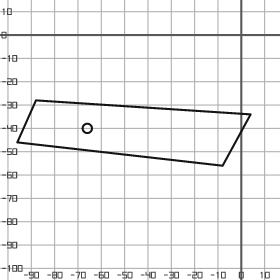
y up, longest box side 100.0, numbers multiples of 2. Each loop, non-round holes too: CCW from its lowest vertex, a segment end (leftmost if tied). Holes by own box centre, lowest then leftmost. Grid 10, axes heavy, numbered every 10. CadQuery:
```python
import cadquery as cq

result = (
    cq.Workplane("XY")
    .moveTo(-8.0, -56.0)
    .lineTo(4.0, -34.0)
    .lineTo(-88.0, -28.0)
    .lineTo(-96.0, -46.0)
    .close()
    .moveTo(-66.0, -40.0)
    .circle(2.0)
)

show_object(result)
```